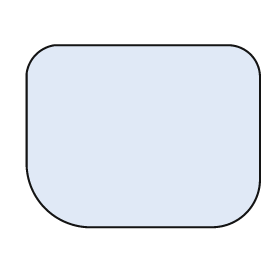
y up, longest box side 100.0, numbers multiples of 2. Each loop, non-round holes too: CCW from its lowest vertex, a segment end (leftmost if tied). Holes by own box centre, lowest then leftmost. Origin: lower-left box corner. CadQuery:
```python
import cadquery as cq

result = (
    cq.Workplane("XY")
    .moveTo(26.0, 0.0)
    .lineTo(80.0, 0.0)
    .threePointArc((94.0, 6.0), (100.0, 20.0))
    .lineTo(100.0, 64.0)
    .threePointArc((96.0, 74.0), (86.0, 78.0))
    .lineTo(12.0, 78.0)
    .threePointArc((4.0, 74.0), (0.0, 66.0))
    .lineTo(0.0, 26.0)
    .threePointArc((8.0, 8.0), (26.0, 0.0))
    .close()
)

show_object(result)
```